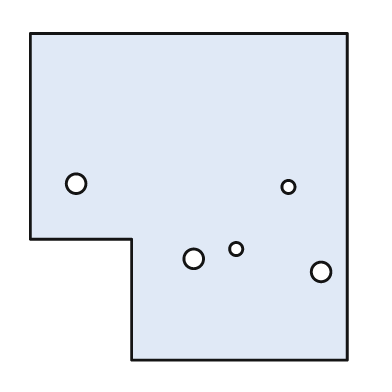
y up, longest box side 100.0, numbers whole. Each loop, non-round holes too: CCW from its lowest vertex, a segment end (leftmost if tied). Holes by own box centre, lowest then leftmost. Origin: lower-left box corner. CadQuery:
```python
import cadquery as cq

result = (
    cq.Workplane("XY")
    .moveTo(31.0, 0.0)
    .lineTo(97.0, 0.0)
    .lineTo(97.0, 100.0)
    .lineTo(0.0, 100.0)
    .lineTo(0.0, 37.0)
    .lineTo(31.0, 37.0)
    .close()
    .moveTo(89.0, 27.0)
    .circle(3.0)
    .moveTo(50.0, 31.0)
    .circle(3.0)
    .moveTo(63.0, 34.0)
    .circle(2.0)
    .moveTo(79.0, 53.0)
    .circle(2.0)
    .moveTo(14.0, 54.0)
    .circle(3.0)
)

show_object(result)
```